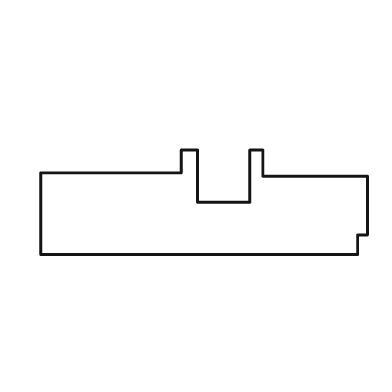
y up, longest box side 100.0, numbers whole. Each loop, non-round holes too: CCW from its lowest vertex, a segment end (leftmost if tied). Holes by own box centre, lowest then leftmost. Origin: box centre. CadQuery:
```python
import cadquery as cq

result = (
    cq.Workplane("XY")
    .moveTo(-50.0, -16.0)
    .lineTo(47.0, -16.0)
    .lineTo(47.0, -10.0)
    .lineTo(50.0, -10.0)
    .lineTo(50.0, 8.0)
    .lineTo(18.0, 8.0)
    .lineTo(18.0, 16.0)
    .lineTo(14.0, 16.0)
    .lineTo(14.0, 0.0)
    .lineTo(-2.0, 0.0)
    .lineTo(-2.0, 16.0)
    .lineTo(-7.0, 16.0)
    .lineTo(-7.0, 9.0)
    .lineTo(-50.0, 9.0)
    .close()
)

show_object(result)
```